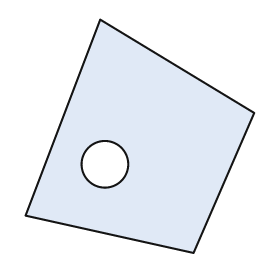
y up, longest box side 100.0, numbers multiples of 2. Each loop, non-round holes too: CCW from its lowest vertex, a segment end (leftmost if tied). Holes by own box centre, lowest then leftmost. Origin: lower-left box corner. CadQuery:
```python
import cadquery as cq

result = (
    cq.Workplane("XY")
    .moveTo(72.0, 0.0)
    .lineTo(98.0, 60.0)
    .lineTo(32.0, 100.0)
    .lineTo(0.0, 16.0)
    .close()
    .moveTo(34.0, 38.0)
    .circle(10.0)
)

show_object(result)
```